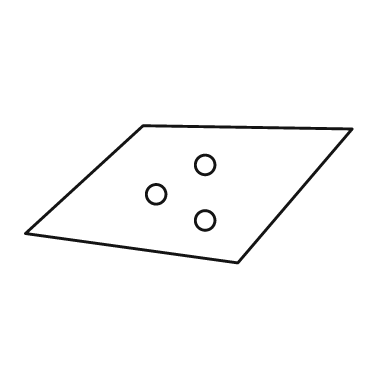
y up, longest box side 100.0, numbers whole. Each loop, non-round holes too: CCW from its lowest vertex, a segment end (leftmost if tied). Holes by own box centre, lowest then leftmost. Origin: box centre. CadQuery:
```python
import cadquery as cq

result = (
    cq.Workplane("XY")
    .moveTo(15.0, -21.0)
    .lineTo(50.0, 20.0)
    .lineTo(-14.0, 21.0)
    .lineTo(-50.0, -12.0)
    .close()
    .moveTo(5.0, -8.0)
    .circle(3.0)
    .moveTo(-10.0, 0.0)
    .circle(3.0)
    .moveTo(5.0, 9.0)
    .circle(3.0)
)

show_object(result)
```